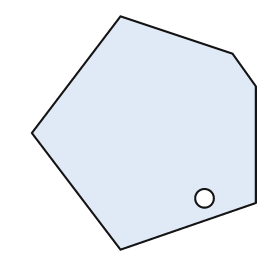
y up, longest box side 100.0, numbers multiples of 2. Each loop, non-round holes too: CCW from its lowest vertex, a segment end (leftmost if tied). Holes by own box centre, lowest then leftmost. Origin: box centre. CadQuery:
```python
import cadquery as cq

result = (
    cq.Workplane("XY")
    .moveTo(-10.0, -50.0)
    .lineTo(48.0, -30.0)
    .lineTo(48.0, 20.0)
    .lineTo(38.0, 34.0)
    .lineTo(-10.0, 50.0)
    .lineTo(-48.0, 0.0)
    .close()
    .moveTo(26.0, -28.0)
    .circle(4.0)
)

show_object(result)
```